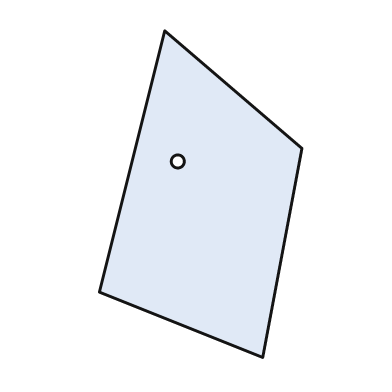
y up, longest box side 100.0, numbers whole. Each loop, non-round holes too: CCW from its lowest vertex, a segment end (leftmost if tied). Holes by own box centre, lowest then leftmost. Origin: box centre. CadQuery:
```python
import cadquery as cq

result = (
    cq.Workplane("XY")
    .moveTo(19.0, -50.0)
    .lineTo(31.0, 14.0)
    .lineTo(-11.0, 50.0)
    .lineTo(-31.0, -30.0)
    .close()
    .moveTo(-7.0, 10.0)
    .circle(2.0)
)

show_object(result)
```